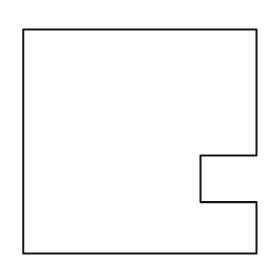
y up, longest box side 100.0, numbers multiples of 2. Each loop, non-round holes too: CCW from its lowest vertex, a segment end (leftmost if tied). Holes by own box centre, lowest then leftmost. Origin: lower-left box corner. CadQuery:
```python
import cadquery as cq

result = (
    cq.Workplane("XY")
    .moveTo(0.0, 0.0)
    .lineTo(100.0, 0.0)
    .lineTo(100.0, 22.0)
    .lineTo(76.0, 22.0)
    .lineTo(76.0, 42.0)
    .lineTo(100.0, 42.0)
    .lineTo(100.0, 96.0)
    .lineTo(0.0, 96.0)
    .close()
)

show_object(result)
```